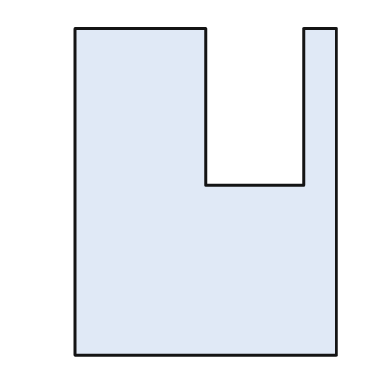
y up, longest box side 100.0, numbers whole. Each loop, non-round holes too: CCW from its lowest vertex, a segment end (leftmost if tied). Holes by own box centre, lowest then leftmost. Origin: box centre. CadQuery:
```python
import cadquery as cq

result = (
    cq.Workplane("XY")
    .moveTo(-40.0, -50.0)
    .lineTo(40.0, -50.0)
    .lineTo(40.0, 50.0)
    .lineTo(30.0, 50.0)
    .lineTo(30.0, 2.0)
    .lineTo(0.0, 2.0)
    .lineTo(0.0, 50.0)
    .lineTo(-40.0, 50.0)
    .close()
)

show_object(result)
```